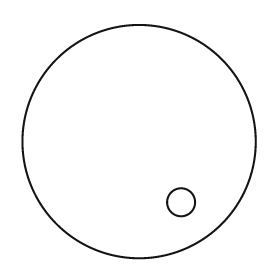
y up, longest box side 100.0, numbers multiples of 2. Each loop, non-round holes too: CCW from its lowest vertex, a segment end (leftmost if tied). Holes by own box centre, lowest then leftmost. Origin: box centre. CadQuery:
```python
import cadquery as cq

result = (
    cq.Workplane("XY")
    .moveTo(0.0, 0.0)
    .circle(50.0)
    .moveTo(18.0, -26.0)
    .circle(6.0)
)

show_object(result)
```